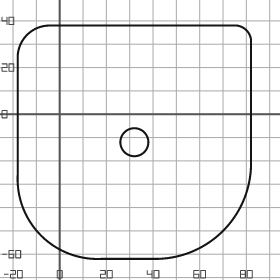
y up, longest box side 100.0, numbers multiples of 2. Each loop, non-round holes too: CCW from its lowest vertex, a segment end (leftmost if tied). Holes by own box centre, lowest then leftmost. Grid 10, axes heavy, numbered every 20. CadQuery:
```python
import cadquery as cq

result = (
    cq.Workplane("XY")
    .moveTo(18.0, -62.0)
    .lineTo(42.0, -62.0)
    .threePointArc((70.0, -50.0), (82.0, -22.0))
    .lineTo(82.0, 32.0)
    .threePointArc((80.0, 36.0), (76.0, 38.0))
    .lineTo(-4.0, 38.0)
    .threePointArc((-14.0, 34.0), (-18.0, 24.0))
    .lineTo(-18.0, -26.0)
    .threePointArc((-8.0, -52.0), (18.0, -62.0))
    .close()
    .moveTo(32.0, -12.0)
    .circle(6.0)
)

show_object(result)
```